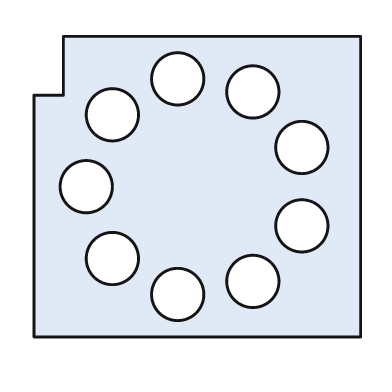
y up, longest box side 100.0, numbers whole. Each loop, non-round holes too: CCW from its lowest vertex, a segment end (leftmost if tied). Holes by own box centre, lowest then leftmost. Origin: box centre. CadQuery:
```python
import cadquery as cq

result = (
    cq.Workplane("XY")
    .moveTo(-50.0, -46.0)
    .lineTo(50.0, -46.0)
    .lineTo(50.0, 46.0)
    .lineTo(-41.0, 46.0)
    .lineTo(-41.0, 28.0)
    .lineTo(-50.0, 28.0)
    .close()
    .moveTo(-6.0, -33.0)
    .circle(8.0)
    .moveTo(17.0, -29.0)
    .circle(8.0)
    .moveTo(-26.0, -22.0)
    .circle(8.0)
    .moveTo(32.0, -12.0)
    .circle(8.0)
    .moveTo(-34.0, 0.0)
    .circle(8.0)
    .moveTo(32.0, 12.0)
    .circle(8.0)
    .moveTo(-26.0, 22.0)
    .circle(8.0)
    .moveTo(17.0, 29.0)
    .circle(8.0)
    .moveTo(-6.0, 33.0)
    .circle(8.0)
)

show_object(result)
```